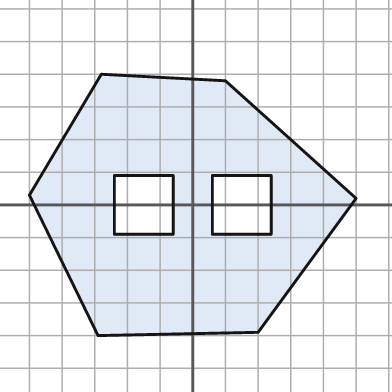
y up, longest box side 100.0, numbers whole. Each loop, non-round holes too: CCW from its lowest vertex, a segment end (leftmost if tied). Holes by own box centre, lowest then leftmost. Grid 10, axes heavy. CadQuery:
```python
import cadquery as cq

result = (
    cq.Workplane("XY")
    .moveTo(-29.0, -40.0)
    .lineTo(20.0, -39.0)
    .lineTo(50.0, 2.0)
    .lineTo(10.0, 38.0)
    .lineTo(-28.0, 40.0)
    .lineTo(-50.0, 3.0)
    .close()
    .moveTo(-24.0, -9.0)
    .lineTo(-6.0, -9.0)
    .lineTo(-6.0, 9.0)
    .lineTo(-24.0, 9.0)
    .close()
    .moveTo(6.0, -9.0)
    .lineTo(24.0, -9.0)
    .lineTo(24.0, 9.0)
    .lineTo(6.0, 9.0)
    .close()
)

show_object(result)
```